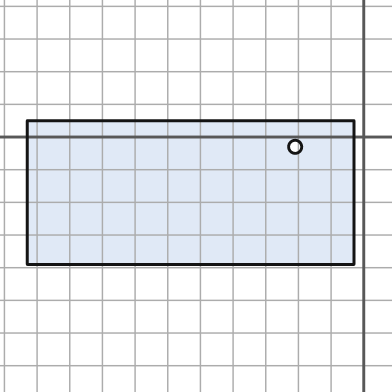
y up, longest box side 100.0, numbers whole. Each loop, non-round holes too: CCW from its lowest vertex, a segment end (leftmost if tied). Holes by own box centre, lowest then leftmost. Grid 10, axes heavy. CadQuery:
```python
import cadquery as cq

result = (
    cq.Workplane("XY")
    .moveTo(-103.0, -39.0)
    .lineTo(-3.0, -39.0)
    .lineTo(-3.0, 5.0)
    .lineTo(-103.0, 5.0)
    .close()
    .moveTo(-21.0, -3.0)
    .circle(2.0)
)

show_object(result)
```